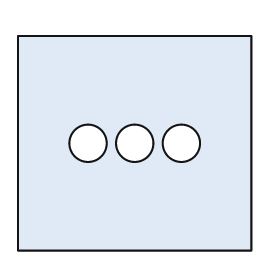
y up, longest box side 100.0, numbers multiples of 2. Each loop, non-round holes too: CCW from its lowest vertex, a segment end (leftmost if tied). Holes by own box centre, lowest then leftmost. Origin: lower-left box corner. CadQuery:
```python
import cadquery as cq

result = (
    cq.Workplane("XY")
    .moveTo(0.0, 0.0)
    .lineTo(100.0, 0.0)
    .lineTo(100.0, 92.0)
    .lineTo(0.0, 92.0)
    .close()
    .moveTo(30.0, 46.0)
    .circle(8.0)
    .moveTo(50.0, 46.0)
    .circle(8.0)
    .moveTo(70.0, 46.0)
    .circle(8.0)
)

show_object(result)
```